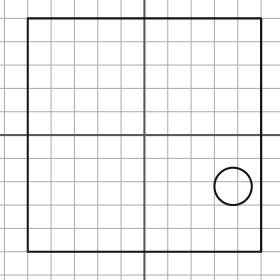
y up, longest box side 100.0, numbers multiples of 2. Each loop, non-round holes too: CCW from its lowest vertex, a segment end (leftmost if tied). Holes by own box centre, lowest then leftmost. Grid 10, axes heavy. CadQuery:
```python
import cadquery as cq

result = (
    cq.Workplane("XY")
    .moveTo(-50.0, -50.0)
    .lineTo(50.0, -50.0)
    .lineTo(50.0, 50.0)
    .lineTo(-50.0, 50.0)
    .close()
    .moveTo(38.0, -22.0)
    .circle(8.0)
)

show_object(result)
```